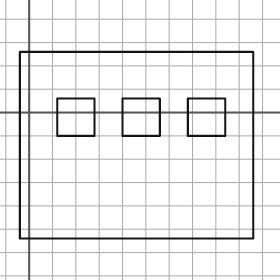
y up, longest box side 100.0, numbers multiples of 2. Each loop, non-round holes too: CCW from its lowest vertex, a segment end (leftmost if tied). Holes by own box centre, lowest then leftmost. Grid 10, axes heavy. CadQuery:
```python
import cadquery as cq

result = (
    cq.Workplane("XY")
    .moveTo(-4.0, -54.0)
    .lineTo(96.0, -54.0)
    .lineTo(96.0, 26.0)
    .lineTo(-4.0, 26.0)
    .close()
    .moveTo(12.0, -10.0)
    .lineTo(28.0, -10.0)
    .lineTo(28.0, 6.0)
    .lineTo(12.0, 6.0)
    .close()
    .moveTo(40.0, -10.0)
    .lineTo(56.0, -10.0)
    .lineTo(56.0, 6.0)
    .lineTo(40.0, 6.0)
    .close()
    .moveTo(68.0, -10.0)
    .lineTo(84.0, -10.0)
    .lineTo(84.0, 6.0)
    .lineTo(68.0, 6.0)
    .close()
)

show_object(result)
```